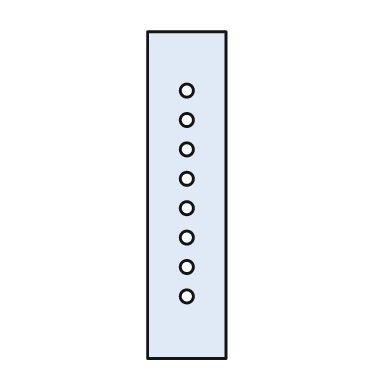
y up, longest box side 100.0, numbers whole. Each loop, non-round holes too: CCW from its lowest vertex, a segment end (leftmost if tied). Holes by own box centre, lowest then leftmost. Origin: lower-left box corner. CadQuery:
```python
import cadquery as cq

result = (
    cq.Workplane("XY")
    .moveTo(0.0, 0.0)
    .lineTo(24.0, 0.0)
    .lineTo(24.0, 100.0)
    .lineTo(0.0, 100.0)
    .close()
    .moveTo(12.0, 19.0)
    .circle(2.0)
    .moveTo(12.0, 28.0)
    .circle(2.0)
    .moveTo(12.0, 37.0)
    .circle(2.0)
    .moveTo(12.0, 46.0)
    .circle(2.0)
    .moveTo(12.0, 55.0)
    .circle(2.0)
    .moveTo(12.0, 64.0)
    .circle(2.0)
    .moveTo(12.0, 73.0)
    .circle(2.0)
    .moveTo(12.0, 82.0)
    .circle(2.0)
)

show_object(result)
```